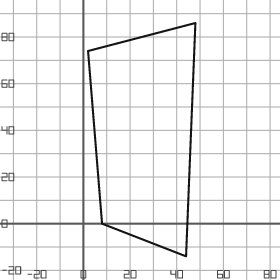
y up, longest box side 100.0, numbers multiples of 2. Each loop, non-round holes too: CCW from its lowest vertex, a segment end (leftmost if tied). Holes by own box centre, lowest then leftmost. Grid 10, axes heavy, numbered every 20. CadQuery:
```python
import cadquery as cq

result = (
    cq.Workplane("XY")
    .moveTo(44.0, -14.0)
    .lineTo(48.0, 86.0)
    .lineTo(2.0, 74.0)
    .lineTo(8.0, 0.0)
    .close()
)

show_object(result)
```